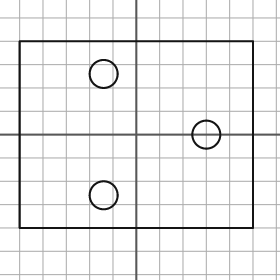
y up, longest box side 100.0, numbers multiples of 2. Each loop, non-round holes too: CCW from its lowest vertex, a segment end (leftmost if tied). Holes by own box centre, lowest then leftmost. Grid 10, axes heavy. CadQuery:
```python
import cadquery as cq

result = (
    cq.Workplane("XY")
    .moveTo(-50.0, -40.0)
    .lineTo(50.0, -40.0)
    .lineTo(50.0, 40.0)
    .lineTo(-50.0, 40.0)
    .close()
    .moveTo(-14.0, -26.0)
    .circle(6.0)
    .moveTo(30.0, 0.0)
    .circle(6.0)
    .moveTo(-14.0, 26.0)
    .circle(6.0)
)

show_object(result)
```